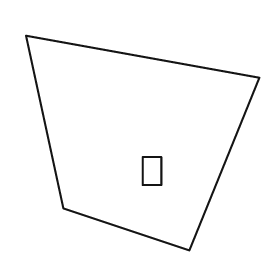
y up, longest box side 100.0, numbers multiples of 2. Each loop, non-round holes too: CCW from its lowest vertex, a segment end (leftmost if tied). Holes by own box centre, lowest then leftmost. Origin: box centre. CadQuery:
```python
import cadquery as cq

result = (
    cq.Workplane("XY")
    .moveTo(20.0, -46.0)
    .lineTo(50.0, 28.0)
    .lineTo(-50.0, 46.0)
    .lineTo(-34.0, -28.0)
    .close()
    .moveTo(0.0, -18.0)
    .lineTo(8.0, -18.0)
    .lineTo(8.0, -6.0)
    .lineTo(0.0, -6.0)
    .close()
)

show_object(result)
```